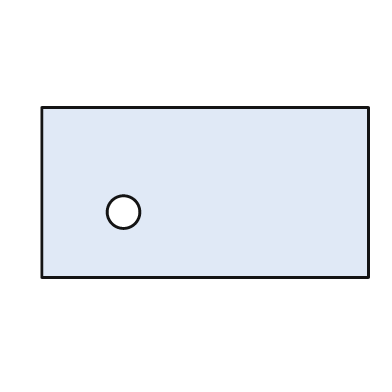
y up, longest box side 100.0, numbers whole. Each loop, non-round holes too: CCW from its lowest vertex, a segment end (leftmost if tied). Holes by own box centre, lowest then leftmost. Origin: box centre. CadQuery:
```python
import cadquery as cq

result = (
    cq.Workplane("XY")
    .moveTo(-50.0, -26.0)
    .lineTo(50.0, -26.0)
    .lineTo(50.0, 26.0)
    .lineTo(-50.0, 26.0)
    .close()
    .moveTo(-25.0, -6.0)
    .circle(5.0)
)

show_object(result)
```